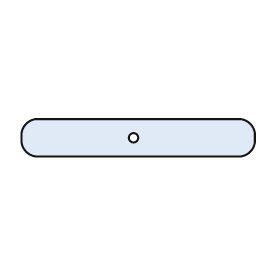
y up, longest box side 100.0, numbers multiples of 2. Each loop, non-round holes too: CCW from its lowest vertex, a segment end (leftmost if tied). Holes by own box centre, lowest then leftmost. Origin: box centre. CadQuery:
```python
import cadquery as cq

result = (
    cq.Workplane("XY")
    .moveTo(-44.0, -8.0)
    .lineTo(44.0, -8.0)
    .threePointArc((48.0, -6.0), (50.0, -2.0))
    .lineTo(50.0, 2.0)
    .threePointArc((48.0, 6.0), (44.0, 8.0))
    .lineTo(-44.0, 8.0)
    .threePointArc((-48.0, 6.0), (-50.0, 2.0))
    .lineTo(-50.0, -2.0)
    .threePointArc((-48.0, -6.0), (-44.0, -8.0))
    .close()
    .moveTo(-2.0, 0.0)
    .circle(2.0)
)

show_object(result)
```